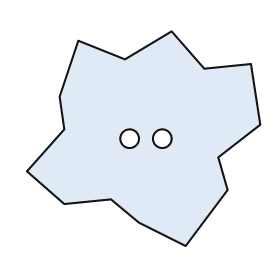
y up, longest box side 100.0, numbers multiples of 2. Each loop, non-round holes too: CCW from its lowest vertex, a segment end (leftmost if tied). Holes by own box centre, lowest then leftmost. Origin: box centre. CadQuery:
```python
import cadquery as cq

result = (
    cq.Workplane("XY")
    .moveTo(18.0, -46.0)
    .lineTo(36.0, -22.0)
    .lineTo(32.0, -8.0)
    .lineTo(50.0, 6.0)
    .lineTo(46.0, 32.0)
    .lineTo(26.0, 30.0)
    .lineTo(12.0, 46.0)
    .lineTo(-8.0, 34.0)
    .lineTo(-28.0, 42.0)
    .lineTo(-36.0, 18.0)
    .lineTo(-34.0, 4.0)
    .lineTo(-50.0, -14.0)
    .lineTo(-34.0, -28.0)
    .lineTo(-14.0, -26.0)
    .lineTo(-2.0, -36.0)
    .close()
    .moveTo(-6.0, 0.0)
    .circle(4.0)
    .moveTo(8.0, 0.0)
    .circle(4.0)
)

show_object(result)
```